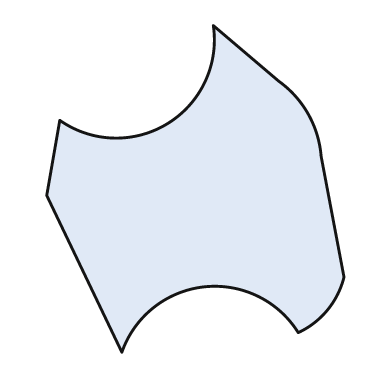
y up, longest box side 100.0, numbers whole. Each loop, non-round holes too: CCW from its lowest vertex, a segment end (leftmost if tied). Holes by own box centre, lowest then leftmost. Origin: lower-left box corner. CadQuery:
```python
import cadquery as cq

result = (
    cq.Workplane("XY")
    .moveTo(23.0, 0.0)
    .threePointArc((48.0, 20.0), (77.0, 6.0))
    .threePointArc((86.0, 13.0), (91.0, 23.0))
    .lineTo(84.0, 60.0)
    .threePointArc((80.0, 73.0), (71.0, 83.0))
    .lineTo(51.0, 100.0)
    .threePointArc((37.0, 70.0), (4.0, 71.0))
    .lineTo(0.0, 48.0)
    .close()
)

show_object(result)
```